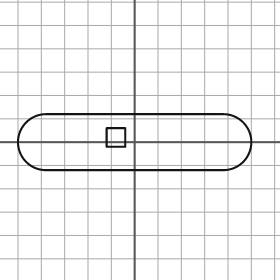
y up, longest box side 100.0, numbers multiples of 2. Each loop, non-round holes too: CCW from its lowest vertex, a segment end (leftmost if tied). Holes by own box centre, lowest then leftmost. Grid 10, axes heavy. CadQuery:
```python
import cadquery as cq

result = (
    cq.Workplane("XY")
    .moveTo(-38.0, -12.0)
    .lineTo(38.0, -12.0)
    .threePointArc((50.0, 0.0), (38.0, 12.0))
    .lineTo(-38.0, 12.0)
    .threePointArc((-50.0, 0.0), (-38.0, -12.0))
    .close()
    .moveTo(-12.0, -2.0)
    .lineTo(-4.0, -2.0)
    .lineTo(-4.0, 6.0)
    .lineTo(-12.0, 6.0)
    .close()
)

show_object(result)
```